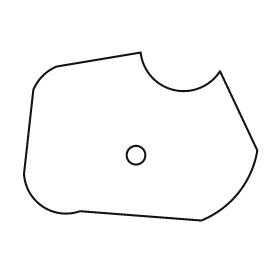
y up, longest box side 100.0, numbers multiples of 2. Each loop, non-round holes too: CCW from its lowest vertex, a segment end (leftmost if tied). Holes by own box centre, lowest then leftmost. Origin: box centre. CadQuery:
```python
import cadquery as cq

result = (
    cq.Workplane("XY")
    .moveTo(26.0, -36.0)
    .threePointArc((42.0, -24.0), (50.0, -6.0))
    .lineTo(34.0, 28.0)
    .threePointArc((14.0, 20.0), (0.0, 36.0))
    .lineTo(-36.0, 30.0)
    .threePointArc((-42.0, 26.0), (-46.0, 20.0))
    .lineTo(-50.0, -16.0)
    .threePointArc((-42.0, -30.0), (-26.0, -32.0))
    .close()
    .moveTo(-2.0, -8.0)
    .circle(4.0)
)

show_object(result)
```